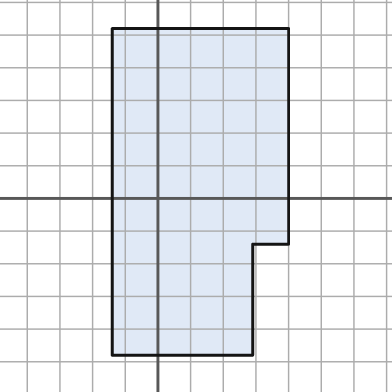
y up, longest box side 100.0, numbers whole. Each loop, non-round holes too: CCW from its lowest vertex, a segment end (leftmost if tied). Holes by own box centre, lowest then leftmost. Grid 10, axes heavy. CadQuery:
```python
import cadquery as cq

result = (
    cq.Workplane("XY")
    .moveTo(-14.0, -48.0)
    .lineTo(29.0, -48.0)
    .lineTo(29.0, -14.0)
    .lineTo(40.0, -14.0)
    .lineTo(40.0, 52.0)
    .lineTo(-14.0, 52.0)
    .close()
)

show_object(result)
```